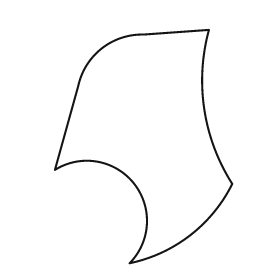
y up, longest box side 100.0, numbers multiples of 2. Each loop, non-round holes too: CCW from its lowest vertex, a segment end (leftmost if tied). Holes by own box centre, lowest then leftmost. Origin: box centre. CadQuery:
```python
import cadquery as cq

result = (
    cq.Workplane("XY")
    .moveTo(-6.0, -50.0)
    .threePointArc((20.0, -38.0), (38.0, -16.0))
    .threePointArc((26.0, 16.0), (28.0, 50.0))
    .lineTo(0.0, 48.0)
    .threePointArc((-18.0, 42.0), (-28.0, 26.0))
    .lineTo(-38.0, -10.0)
    .threePointArc((-4.0, -16.0), (-6.0, -50.0))
    .close()
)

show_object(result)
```